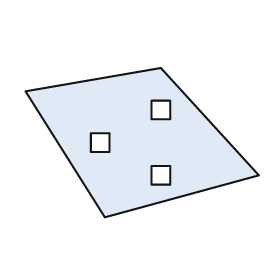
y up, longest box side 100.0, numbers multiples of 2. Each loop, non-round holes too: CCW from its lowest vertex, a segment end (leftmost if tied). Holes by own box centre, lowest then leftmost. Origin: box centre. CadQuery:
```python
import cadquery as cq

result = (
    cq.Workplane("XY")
    .moveTo(-16.0, -32.0)
    .lineTo(50.0, -14.0)
    .lineTo(8.0, 32.0)
    .lineTo(-50.0, 22.0)
    .close()
    .moveTo(4.0, -18.0)
    .lineTo(12.0, -18.0)
    .lineTo(12.0, -10.0)
    .lineTo(4.0, -10.0)
    .close()
    .moveTo(-22.0, -4.0)
    .lineTo(-14.0, -4.0)
    .lineTo(-14.0, 4.0)
    .lineTo(-22.0, 4.0)
    .close()
    .moveTo(4.0, 10.0)
    .lineTo(12.0, 10.0)
    .lineTo(12.0, 18.0)
    .lineTo(4.0, 18.0)
    .close()
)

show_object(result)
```